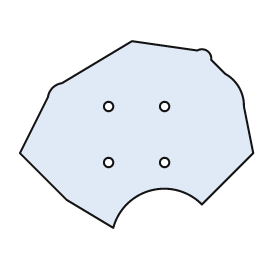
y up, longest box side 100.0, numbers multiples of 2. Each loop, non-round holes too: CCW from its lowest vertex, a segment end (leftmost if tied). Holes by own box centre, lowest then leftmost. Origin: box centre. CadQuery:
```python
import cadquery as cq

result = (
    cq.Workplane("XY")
    .moveTo(-10.0, -40.0)
    .threePointArc((6.0, -24.0), (28.0, -30.0))
    .lineTo(50.0, -8.0)
    .lineTo(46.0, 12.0)
    .threePointArc((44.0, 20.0), (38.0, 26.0))
    .lineTo(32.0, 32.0)
    .threePointArc((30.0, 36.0), (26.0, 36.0))
    .lineTo(-2.0, 40.0)
    .lineTo(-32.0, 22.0)
    .threePointArc((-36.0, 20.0), (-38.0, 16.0))
    .lineTo(-50.0, -8.0)
    .lineTo(-30.0, -28.0)
    .close()
    .moveTo(-12.0, -12.0)
    .circle(2.0)
    .moveTo(12.0, -12.0)
    .circle(2.0)
    .moveTo(-12.0, 12.0)
    .circle(2.0)
    .moveTo(12.0, 12.0)
    .circle(2.0)
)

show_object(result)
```